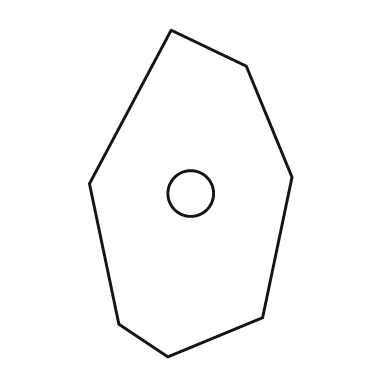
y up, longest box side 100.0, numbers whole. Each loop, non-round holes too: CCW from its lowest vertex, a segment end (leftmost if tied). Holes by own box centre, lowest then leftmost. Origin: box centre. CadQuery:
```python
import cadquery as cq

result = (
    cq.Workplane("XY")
    .moveTo(-7.0, -50.0)
    .lineTo(22.0, -38.0)
    .lineTo(31.0, 5.0)
    .lineTo(17.0, 39.0)
    .lineTo(-6.0, 50.0)
    .lineTo(-31.0, 3.0)
    .lineTo(-22.0, -40.0)
    .close()
    .moveTo(0.0, 0.0)
    .circle(7.0)
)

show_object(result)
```